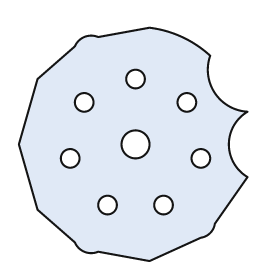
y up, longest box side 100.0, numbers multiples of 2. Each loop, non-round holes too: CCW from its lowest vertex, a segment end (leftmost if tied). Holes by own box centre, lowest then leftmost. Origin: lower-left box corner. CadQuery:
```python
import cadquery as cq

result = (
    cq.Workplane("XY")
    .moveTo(56.0, 0.0)
    .lineTo(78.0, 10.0)
    .threePointArc((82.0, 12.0), (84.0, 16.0))
    .lineTo(98.0, 36.0)
    .threePointArc((90.0, 50.0), (98.0, 64.0))
    .threePointArc((84.0, 72.0), (82.0, 88.0))
    .threePointArc((70.0, 96.0), (56.0, 100.0))
    .lineTo(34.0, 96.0)
    .threePointArc((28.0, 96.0), (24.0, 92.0))
    .lineTo(8.0, 78.0)
    .lineTo(0.0, 50.0)
    .lineTo(8.0, 22.0)
    .lineTo(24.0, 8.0)
    .threePointArc((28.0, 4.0), (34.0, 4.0))
    .close()
    .moveTo(38.0, 24.0)
    .circle(4.0)
    .moveTo(62.0, 24.0)
    .circle(4.0)
    .moveTo(22.0, 44.0)
    .circle(4.0)
    .moveTo(78.0, 44.0)
    .circle(4.0)
    .moveTo(50.0, 50.0)
    .circle(6.0)
    .moveTo(28.0, 68.0)
    .circle(4.0)
    .moveTo(72.0, 68.0)
    .circle(4.0)
    .moveTo(50.0, 78.0)
    .circle(4.0)
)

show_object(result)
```